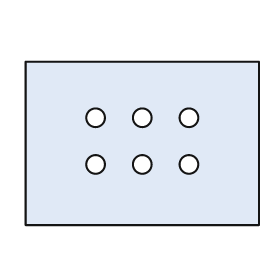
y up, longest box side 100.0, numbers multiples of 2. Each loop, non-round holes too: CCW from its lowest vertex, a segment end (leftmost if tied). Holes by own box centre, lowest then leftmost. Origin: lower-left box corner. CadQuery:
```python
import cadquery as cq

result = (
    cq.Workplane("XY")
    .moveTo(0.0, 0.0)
    .lineTo(100.0, 0.0)
    .lineTo(100.0, 70.0)
    .lineTo(0.0, 70.0)
    .close()
    .moveTo(30.0, 26.0)
    .circle(4.0)
    .moveTo(50.0, 26.0)
    .circle(4.0)
    .moveTo(70.0, 26.0)
    .circle(4.0)
    .moveTo(30.0, 46.0)
    .circle(4.0)
    .moveTo(50.0, 46.0)
    .circle(4.0)
    .moveTo(70.0, 46.0)
    .circle(4.0)
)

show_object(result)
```